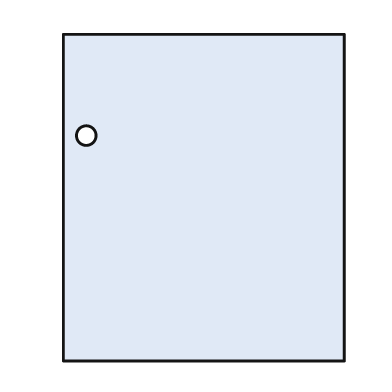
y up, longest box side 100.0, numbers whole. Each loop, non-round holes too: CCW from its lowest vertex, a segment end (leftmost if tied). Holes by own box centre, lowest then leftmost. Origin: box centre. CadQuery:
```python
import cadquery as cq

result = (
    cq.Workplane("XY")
    .moveTo(-43.0, -50.0)
    .lineTo(43.0, -50.0)
    .lineTo(43.0, 50.0)
    .lineTo(-43.0, 50.0)
    .close()
    .moveTo(-36.0, 19.0)
    .circle(3.0)
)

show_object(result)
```